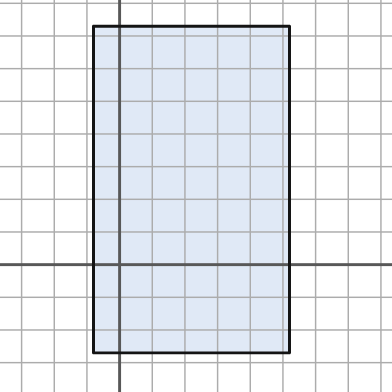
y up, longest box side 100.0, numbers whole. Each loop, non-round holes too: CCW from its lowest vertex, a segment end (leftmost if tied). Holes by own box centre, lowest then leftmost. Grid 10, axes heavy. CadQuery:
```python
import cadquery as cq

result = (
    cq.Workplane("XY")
    .moveTo(-8.0, -27.0)
    .lineTo(52.0, -27.0)
    .lineTo(52.0, 73.0)
    .lineTo(-8.0, 73.0)
    .close()
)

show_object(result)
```